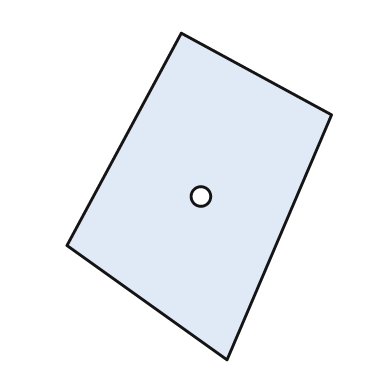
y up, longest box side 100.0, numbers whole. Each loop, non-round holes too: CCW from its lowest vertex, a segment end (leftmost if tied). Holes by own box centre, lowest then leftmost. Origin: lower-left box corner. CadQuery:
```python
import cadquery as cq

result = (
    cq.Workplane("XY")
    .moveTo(49.0, 0.0)
    .lineTo(81.0, 75.0)
    .lineTo(35.0, 100.0)
    .lineTo(0.0, 35.0)
    .close()
    .moveTo(41.0, 50.0)
    .circle(3.0)
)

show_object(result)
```